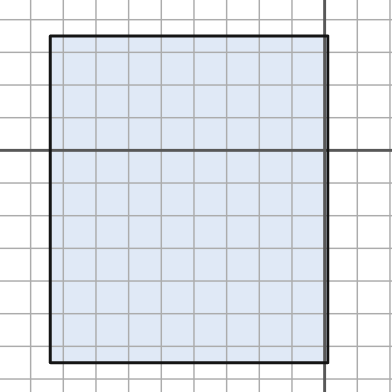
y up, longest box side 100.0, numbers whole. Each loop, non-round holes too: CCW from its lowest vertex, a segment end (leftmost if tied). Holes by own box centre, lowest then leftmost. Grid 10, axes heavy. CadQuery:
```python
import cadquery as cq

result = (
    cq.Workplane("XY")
    .moveTo(-84.0, -65.0)
    .lineTo(1.0, -65.0)
    .lineTo(1.0, 35.0)
    .lineTo(-84.0, 35.0)
    .close()
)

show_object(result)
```